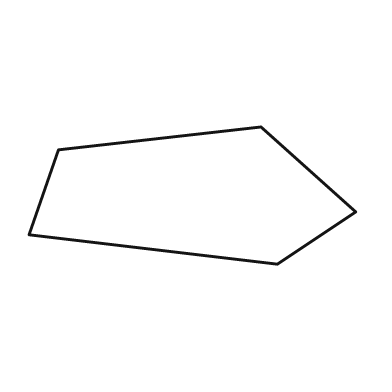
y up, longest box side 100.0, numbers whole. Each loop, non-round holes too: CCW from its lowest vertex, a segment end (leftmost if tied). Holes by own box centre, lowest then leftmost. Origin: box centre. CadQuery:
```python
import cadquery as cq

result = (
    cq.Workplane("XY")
    .moveTo(26.0, -21.0)
    .lineTo(50.0, -5.0)
    .lineTo(21.0, 21.0)
    .lineTo(-41.0, 14.0)
    .lineTo(-50.0, -12.0)
    .close()
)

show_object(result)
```